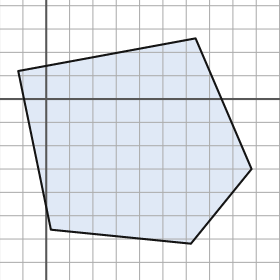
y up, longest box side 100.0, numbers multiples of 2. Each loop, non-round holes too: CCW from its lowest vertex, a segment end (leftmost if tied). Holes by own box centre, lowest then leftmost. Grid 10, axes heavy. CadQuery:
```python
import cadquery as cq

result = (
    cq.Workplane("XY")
    .moveTo(62.0, -62.0)
    .lineTo(88.0, -30.0)
    .lineTo(64.0, 26.0)
    .lineTo(-12.0, 12.0)
    .lineTo(2.0, -56.0)
    .close()
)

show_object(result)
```